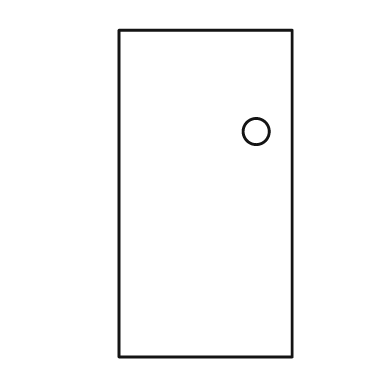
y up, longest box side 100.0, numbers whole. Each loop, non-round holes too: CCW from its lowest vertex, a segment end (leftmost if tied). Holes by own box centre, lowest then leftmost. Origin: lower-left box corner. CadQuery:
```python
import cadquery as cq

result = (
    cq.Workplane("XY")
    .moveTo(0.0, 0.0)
    .lineTo(53.0, 0.0)
    .lineTo(53.0, 100.0)
    .lineTo(0.0, 100.0)
    .close()
    .moveTo(42.0, 69.0)
    .circle(4.0)
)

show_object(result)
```